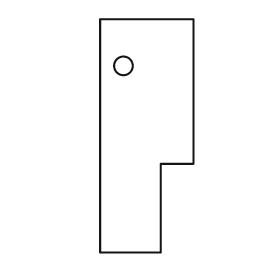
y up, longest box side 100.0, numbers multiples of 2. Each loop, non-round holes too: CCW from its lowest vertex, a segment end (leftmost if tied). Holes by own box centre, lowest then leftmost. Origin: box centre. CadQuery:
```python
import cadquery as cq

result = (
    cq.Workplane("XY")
    .moveTo(-20.0, -50.0)
    .lineTo(6.0, -50.0)
    .lineTo(6.0, -12.0)
    .lineTo(20.0, -12.0)
    .lineTo(20.0, 50.0)
    .lineTo(-20.0, 50.0)
    .close()
    .moveTo(-10.0, 30.0)
    .circle(4.0)
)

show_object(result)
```